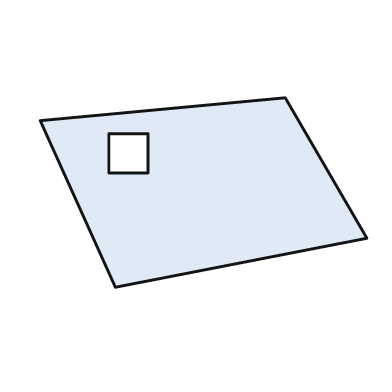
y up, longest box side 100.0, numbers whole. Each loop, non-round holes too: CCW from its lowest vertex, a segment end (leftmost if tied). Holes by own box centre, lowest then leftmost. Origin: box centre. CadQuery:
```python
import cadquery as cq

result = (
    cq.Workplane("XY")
    .moveTo(-27.0, -29.0)
    .lineTo(50.0, -14.0)
    .lineTo(25.0, 29.0)
    .lineTo(-50.0, 22.0)
    .close()
    .moveTo(-29.0, 6.0)
    .lineTo(-17.0, 6.0)
    .lineTo(-17.0, 18.0)
    .lineTo(-29.0, 18.0)
    .close()
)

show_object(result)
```